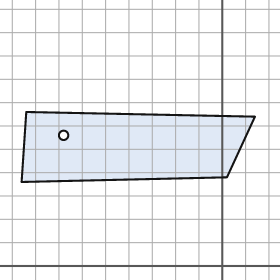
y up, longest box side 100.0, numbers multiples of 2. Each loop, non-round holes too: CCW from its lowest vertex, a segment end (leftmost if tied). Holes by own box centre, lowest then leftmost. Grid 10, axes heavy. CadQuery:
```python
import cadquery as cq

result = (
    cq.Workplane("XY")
    .moveTo(-86.0, 36.0)
    .lineTo(2.0, 38.0)
    .lineTo(14.0, 64.0)
    .lineTo(-84.0, 66.0)
    .close()
    .moveTo(-68.0, 56.0)
    .circle(2.0)
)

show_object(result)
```